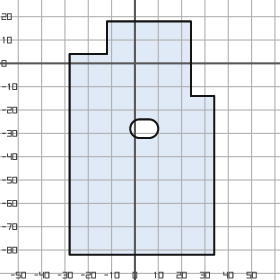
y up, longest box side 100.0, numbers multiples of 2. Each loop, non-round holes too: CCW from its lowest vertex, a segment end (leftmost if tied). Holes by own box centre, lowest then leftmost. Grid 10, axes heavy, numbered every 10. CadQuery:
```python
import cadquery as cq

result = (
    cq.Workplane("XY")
    .moveTo(-28.0, -82.0)
    .lineTo(34.0, -82.0)
    .lineTo(34.0, -14.0)
    .lineTo(24.0, -14.0)
    .lineTo(24.0, 18.0)
    .lineTo(-12.0, 18.0)
    .lineTo(-12.0, 4.0)
    .lineTo(-28.0, 4.0)
    .close()
    .moveTo(2.0, -32.0)
    .lineTo(6.0, -32.0)
    .threePointArc((10.0, -28.0), (6.0, -24.0))
    .lineTo(2.0, -24.0)
    .threePointArc((-2.0, -28.0), (2.0, -32.0))
    .close()
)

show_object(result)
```